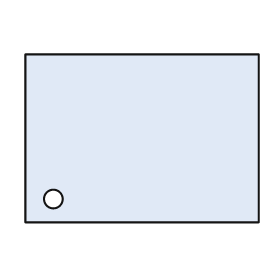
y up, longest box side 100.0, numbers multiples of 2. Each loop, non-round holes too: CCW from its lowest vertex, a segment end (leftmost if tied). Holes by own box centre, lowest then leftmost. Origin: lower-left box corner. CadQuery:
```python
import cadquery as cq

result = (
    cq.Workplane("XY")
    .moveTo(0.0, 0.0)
    .lineTo(100.0, 0.0)
    .lineTo(100.0, 72.0)
    .lineTo(0.0, 72.0)
    .close()
    .moveTo(12.0, 10.0)
    .circle(4.0)
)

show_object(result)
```